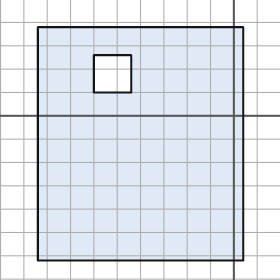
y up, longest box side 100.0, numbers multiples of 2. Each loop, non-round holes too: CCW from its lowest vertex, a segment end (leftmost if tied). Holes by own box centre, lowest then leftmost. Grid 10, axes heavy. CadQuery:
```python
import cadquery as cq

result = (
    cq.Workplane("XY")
    .moveTo(-84.0, -62.0)
    .lineTo(4.0, -62.0)
    .lineTo(4.0, 38.0)
    .lineTo(-84.0, 38.0)
    .close()
    .moveTo(-60.0, 10.0)
    .lineTo(-44.0, 10.0)
    .lineTo(-44.0, 26.0)
    .lineTo(-60.0, 26.0)
    .close()
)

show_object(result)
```